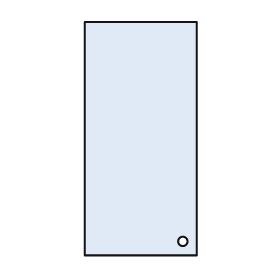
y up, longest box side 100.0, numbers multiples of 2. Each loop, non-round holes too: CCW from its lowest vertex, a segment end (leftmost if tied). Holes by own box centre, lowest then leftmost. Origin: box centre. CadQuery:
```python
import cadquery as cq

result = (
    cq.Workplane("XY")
    .moveTo(-24.0, -50.0)
    .lineTo(24.0, -50.0)
    .lineTo(24.0, 50.0)
    .lineTo(-24.0, 50.0)
    .close()
    .moveTo(18.0, -44.0)
    .circle(2.0)
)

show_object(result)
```